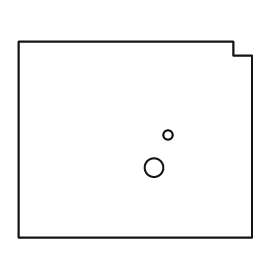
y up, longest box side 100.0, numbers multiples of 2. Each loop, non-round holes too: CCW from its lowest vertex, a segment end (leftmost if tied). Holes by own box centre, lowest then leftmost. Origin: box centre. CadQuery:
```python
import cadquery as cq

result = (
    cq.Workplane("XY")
    .moveTo(-50.0, -42.0)
    .lineTo(50.0, -42.0)
    .lineTo(50.0, 36.0)
    .lineTo(42.0, 36.0)
    .lineTo(42.0, 42.0)
    .lineTo(-50.0, 42.0)
    .close()
    .moveTo(8.0, -12.0)
    .circle(4.0)
    .moveTo(14.0, 2.0)
    .circle(2.0)
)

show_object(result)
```